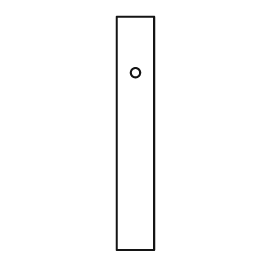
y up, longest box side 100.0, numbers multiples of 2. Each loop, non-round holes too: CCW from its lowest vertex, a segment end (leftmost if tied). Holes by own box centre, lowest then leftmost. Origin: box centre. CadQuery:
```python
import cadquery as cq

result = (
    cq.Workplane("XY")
    .moveTo(-8.0, -50.0)
    .lineTo(8.0, -50.0)
    .lineTo(8.0, 50.0)
    .lineTo(-8.0, 50.0)
    .close()
    .moveTo(0.0, 26.0)
    .circle(2.0)
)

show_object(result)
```